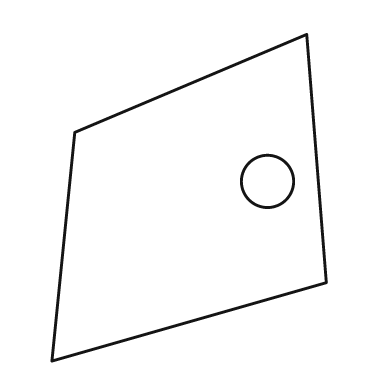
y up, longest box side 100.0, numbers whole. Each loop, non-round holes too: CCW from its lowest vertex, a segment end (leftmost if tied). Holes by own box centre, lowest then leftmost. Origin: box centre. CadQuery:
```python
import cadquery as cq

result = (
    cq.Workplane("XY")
    .moveTo(-42.0, -50.0)
    .lineTo(42.0, -26.0)
    .lineTo(36.0, 50.0)
    .lineTo(-35.0, 20.0)
    .close()
    .moveTo(24.0, 5.0)
    .circle(8.0)
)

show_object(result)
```